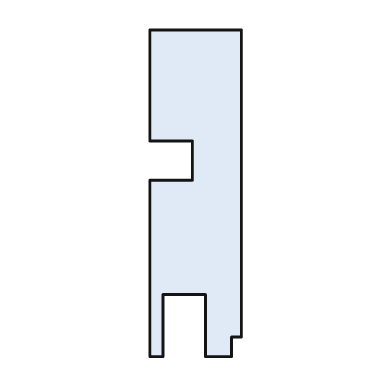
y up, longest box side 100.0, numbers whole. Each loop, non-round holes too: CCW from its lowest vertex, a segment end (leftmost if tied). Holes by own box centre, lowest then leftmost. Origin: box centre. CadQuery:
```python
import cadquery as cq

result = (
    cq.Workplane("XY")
    .moveTo(-14.0, -50.0)
    .lineTo(-10.0, -50.0)
    .lineTo(-10.0, -31.0)
    .lineTo(3.0, -31.0)
    .lineTo(3.0, -50.0)
    .lineTo(11.0, -50.0)
    .lineTo(11.0, -44.0)
    .lineTo(14.0, -44.0)
    .lineTo(14.0, 50.0)
    .lineTo(-14.0, 50.0)
    .lineTo(-14.0, 16.0)
    .lineTo(-1.0, 16.0)
    .lineTo(-1.0, 4.0)
    .lineTo(-14.0, 4.0)
    .close()
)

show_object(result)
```